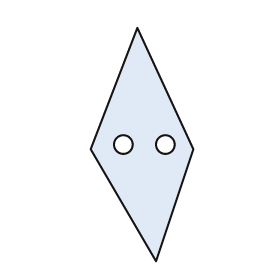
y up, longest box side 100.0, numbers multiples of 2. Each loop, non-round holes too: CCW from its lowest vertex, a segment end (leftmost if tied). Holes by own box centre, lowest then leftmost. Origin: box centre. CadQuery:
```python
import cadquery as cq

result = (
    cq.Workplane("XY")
    .moveTo(6.0, -50.0)
    .lineTo(22.0, -2.0)
    .lineTo(-2.0, 50.0)
    .lineTo(-22.0, -2.0)
    .close()
    .moveTo(-8.0, 0.0)
    .circle(4.0)
    .moveTo(10.0, 0.0)
    .circle(4.0)
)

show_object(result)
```